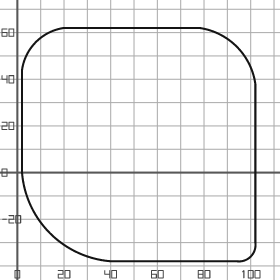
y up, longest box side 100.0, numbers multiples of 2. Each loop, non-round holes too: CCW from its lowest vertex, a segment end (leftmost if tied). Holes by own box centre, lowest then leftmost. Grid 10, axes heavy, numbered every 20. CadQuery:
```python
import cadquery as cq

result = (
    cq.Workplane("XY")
    .moveTo(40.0, -38.0)
    .lineTo(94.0, -38.0)
    .threePointArc((100.0, -36.0), (102.0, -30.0))
    .lineTo(102.0, 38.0)
    .threePointArc((94.0, 54.0), (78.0, 62.0))
    .lineTo(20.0, 62.0)
    .threePointArc((8.0, 56.0), (2.0, 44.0))
    .lineTo(2.0, 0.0)
    .threePointArc((14.0, -26.0), (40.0, -38.0))
    .close()
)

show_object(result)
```